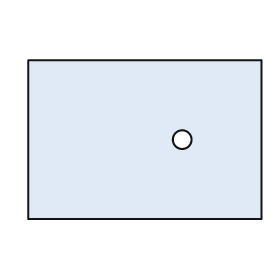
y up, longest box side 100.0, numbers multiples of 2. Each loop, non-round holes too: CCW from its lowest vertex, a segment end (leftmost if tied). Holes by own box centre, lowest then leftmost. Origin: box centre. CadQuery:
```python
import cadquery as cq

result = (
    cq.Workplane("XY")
    .moveTo(-50.0, -34.0)
    .lineTo(50.0, -34.0)
    .lineTo(50.0, 34.0)
    .lineTo(-50.0, 34.0)
    .close()
    .moveTo(16.0, 0.0)
    .circle(4.0)
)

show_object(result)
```